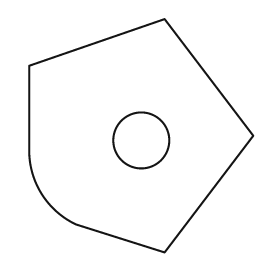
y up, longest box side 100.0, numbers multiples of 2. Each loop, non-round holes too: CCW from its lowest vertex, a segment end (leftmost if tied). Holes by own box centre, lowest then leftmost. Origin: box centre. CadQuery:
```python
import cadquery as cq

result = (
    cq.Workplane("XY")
    .moveTo(10.0, -50.0)
    .lineTo(48.0, 0.0)
    .lineTo(10.0, 50.0)
    .lineTo(-48.0, 30.0)
    .lineTo(-48.0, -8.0)
    .threePointArc((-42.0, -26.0), (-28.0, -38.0))
    .close()
    .moveTo(0.0, -2.0)
    .circle(12.0)
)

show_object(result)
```